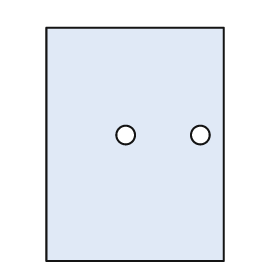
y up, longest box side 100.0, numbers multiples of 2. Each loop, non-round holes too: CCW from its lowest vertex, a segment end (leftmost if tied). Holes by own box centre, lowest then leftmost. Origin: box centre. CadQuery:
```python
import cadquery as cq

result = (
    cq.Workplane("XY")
    .moveTo(-38.0, -50.0)
    .lineTo(38.0, -50.0)
    .lineTo(38.0, 50.0)
    .lineTo(-38.0, 50.0)
    .close()
    .moveTo(-4.0, 4.0)
    .circle(4.0)
    .moveTo(28.0, 4.0)
    .circle(4.0)
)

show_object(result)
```